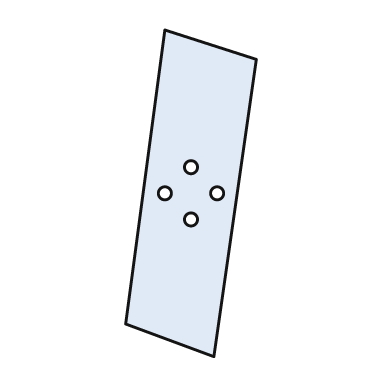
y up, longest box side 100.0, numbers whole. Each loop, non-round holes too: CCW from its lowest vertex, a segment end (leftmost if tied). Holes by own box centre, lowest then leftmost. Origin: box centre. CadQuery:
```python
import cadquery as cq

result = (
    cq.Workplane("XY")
    .moveTo(7.0, -50.0)
    .lineTo(20.0, 41.0)
    .lineTo(-8.0, 50.0)
    .lineTo(-20.0, -40.0)
    .close()
    .moveTo(0.0, -8.0)
    .circle(2.0)
    .moveTo(-8.0, 0.0)
    .circle(2.0)
    .moveTo(8.0, 0.0)
    .circle(2.0)
    .moveTo(0.0, 8.0)
    .circle(2.0)
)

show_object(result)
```